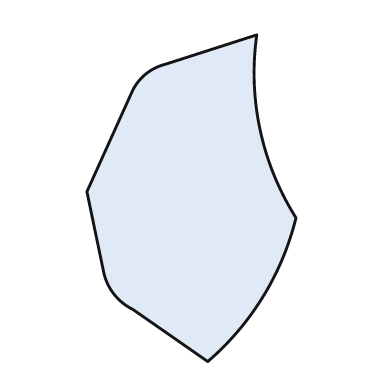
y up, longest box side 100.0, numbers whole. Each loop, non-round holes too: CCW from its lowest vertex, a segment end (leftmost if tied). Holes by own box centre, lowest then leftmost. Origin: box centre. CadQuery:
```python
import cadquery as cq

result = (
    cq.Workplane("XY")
    .moveTo(5.0, -50.0)
    .threePointArc((22.0, -30.0), (32.0, -6.0))
    .threePointArc((21.0, 21.0), (20.0, 50.0))
    .lineTo(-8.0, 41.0)
    .threePointArc((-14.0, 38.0), (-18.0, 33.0))
    .lineTo(-32.0, 2.0)
    .lineTo(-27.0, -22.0)
    .threePointArc((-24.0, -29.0), (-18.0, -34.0))
    .close()
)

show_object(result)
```